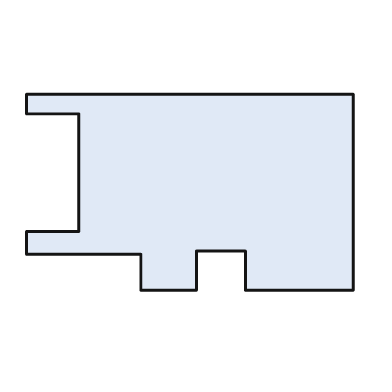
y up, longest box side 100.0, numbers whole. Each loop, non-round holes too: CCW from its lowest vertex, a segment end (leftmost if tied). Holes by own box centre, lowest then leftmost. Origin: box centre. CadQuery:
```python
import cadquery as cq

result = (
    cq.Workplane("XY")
    .moveTo(-15.0, -30.0)
    .lineTo(2.0, -30.0)
    .lineTo(2.0, -18.0)
    .lineTo(17.0, -18.0)
    .lineTo(17.0, -30.0)
    .lineTo(50.0, -30.0)
    .lineTo(50.0, 30.0)
    .lineTo(-50.0, 30.0)
    .lineTo(-50.0, 24.0)
    .lineTo(-34.0, 24.0)
    .lineTo(-34.0, -12.0)
    .lineTo(-50.0, -12.0)
    .lineTo(-50.0, -19.0)
    .lineTo(-15.0, -19.0)
    .close()
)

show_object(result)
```